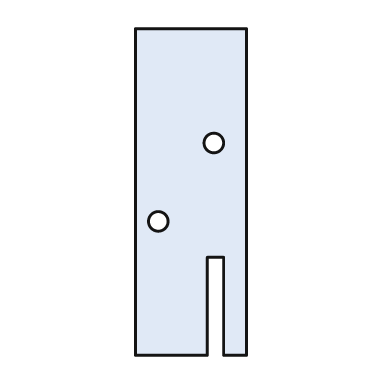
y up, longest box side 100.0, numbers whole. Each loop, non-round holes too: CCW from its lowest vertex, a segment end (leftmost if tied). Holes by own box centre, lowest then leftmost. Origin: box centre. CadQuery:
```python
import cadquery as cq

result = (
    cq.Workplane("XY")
    .moveTo(-17.0, -50.0)
    .lineTo(5.0, -50.0)
    .lineTo(5.0, -20.0)
    .lineTo(10.0, -20.0)
    .lineTo(10.0, -50.0)
    .lineTo(17.0, -50.0)
    .lineTo(17.0, 50.0)
    .lineTo(-17.0, 50.0)
    .close()
    .moveTo(-10.0, -9.0)
    .circle(3.0)
    .moveTo(7.0, 15.0)
    .circle(3.0)
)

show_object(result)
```